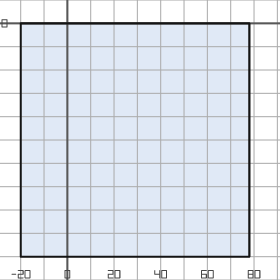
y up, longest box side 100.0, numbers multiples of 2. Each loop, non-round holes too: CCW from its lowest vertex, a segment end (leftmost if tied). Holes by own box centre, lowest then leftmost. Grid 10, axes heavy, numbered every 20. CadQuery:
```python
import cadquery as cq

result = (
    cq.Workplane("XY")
    .moveTo(-20.0, -100.0)
    .lineTo(78.0, -100.0)
    .lineTo(78.0, 0.0)
    .lineTo(-20.0, 0.0)
    .close()
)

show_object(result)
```